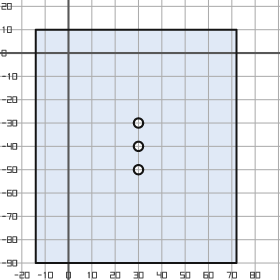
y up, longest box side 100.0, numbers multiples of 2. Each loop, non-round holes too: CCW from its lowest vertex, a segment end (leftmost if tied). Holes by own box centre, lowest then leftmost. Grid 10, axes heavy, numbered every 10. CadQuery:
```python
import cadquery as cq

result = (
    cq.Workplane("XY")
    .moveTo(-14.0, -90.0)
    .lineTo(72.0, -90.0)
    .lineTo(72.0, 10.0)
    .lineTo(-14.0, 10.0)
    .close()
    .moveTo(30.0, -50.0)
    .circle(2.0)
    .moveTo(30.0, -40.0)
    .circle(2.0)
    .moveTo(30.0, -30.0)
    .circle(2.0)
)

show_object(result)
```